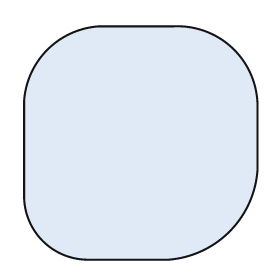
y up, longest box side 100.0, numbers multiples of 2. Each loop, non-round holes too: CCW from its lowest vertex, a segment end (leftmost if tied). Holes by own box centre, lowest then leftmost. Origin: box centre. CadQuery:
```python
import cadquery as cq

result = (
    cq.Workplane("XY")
    .moveTo(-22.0, -50.0)
    .lineTo(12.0, -50.0)
    .threePointArc((38.0, -38.0), (50.0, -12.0))
    .lineTo(50.0, 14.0)
    .threePointArc((40.0, 40.0), (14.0, 50.0))
    .lineTo(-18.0, 50.0)
    .threePointArc((-40.0, 40.0), (-50.0, 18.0))
    .lineTo(-50.0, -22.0)
    .threePointArc((-42.0, -42.0), (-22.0, -50.0))
    .close()
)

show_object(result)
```